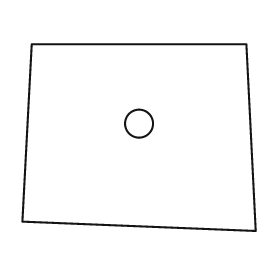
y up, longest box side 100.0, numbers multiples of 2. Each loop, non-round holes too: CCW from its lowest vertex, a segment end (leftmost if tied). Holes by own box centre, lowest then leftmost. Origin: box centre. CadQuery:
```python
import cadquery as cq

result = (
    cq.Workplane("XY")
    .moveTo(50.0, -40.0)
    .lineTo(46.0, 40.0)
    .lineTo(-46.0, 40.0)
    .lineTo(-50.0, -36.0)
    .close()
    .moveTo(0.0, 6.0)
    .circle(6.0)
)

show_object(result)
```